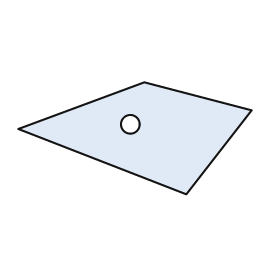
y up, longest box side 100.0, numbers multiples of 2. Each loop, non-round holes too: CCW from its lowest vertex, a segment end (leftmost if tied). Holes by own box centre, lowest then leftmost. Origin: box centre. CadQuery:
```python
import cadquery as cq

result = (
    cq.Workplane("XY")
    .moveTo(22.0, -24.0)
    .lineTo(50.0, 12.0)
    .lineTo(4.0, 24.0)
    .lineTo(-50.0, 4.0)
    .close()
    .moveTo(-2.0, 6.0)
    .circle(4.0)
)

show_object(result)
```